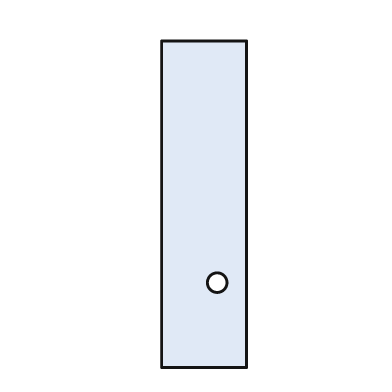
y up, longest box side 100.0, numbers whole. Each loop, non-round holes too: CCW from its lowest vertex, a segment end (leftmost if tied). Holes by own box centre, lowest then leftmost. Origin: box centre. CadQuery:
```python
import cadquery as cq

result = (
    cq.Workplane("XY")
    .moveTo(-13.0, -50.0)
    .lineTo(13.0, -50.0)
    .lineTo(13.0, 50.0)
    .lineTo(-13.0, 50.0)
    .close()
    .moveTo(4.0, -24.0)
    .circle(3.0)
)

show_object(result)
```